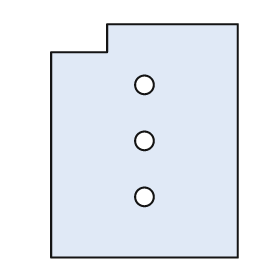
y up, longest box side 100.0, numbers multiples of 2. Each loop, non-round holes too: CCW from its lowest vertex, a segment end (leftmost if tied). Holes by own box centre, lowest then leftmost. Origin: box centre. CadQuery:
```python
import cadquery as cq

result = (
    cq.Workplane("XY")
    .moveTo(-40.0, -50.0)
    .lineTo(40.0, -50.0)
    .lineTo(40.0, 50.0)
    .lineTo(-16.0, 50.0)
    .lineTo(-16.0, 38.0)
    .lineTo(-40.0, 38.0)
    .close()
    .moveTo(0.0, -24.0)
    .circle(4.0)
    .moveTo(0.0, 0.0)
    .circle(4.0)
    .moveTo(0.0, 24.0)
    .circle(4.0)
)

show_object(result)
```